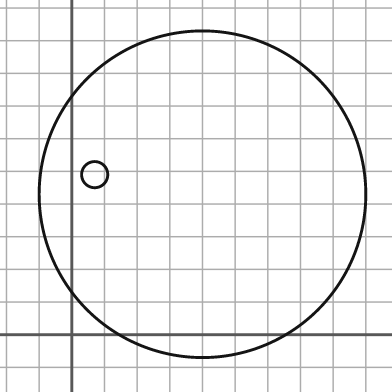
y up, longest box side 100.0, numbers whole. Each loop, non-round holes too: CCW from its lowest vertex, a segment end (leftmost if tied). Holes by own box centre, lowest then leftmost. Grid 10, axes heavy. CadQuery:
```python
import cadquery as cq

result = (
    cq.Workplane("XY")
    .moveTo(40.0, 43.0)
    .circle(50.0)
    .moveTo(7.0, 49.0)
    .circle(4.0)
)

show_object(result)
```